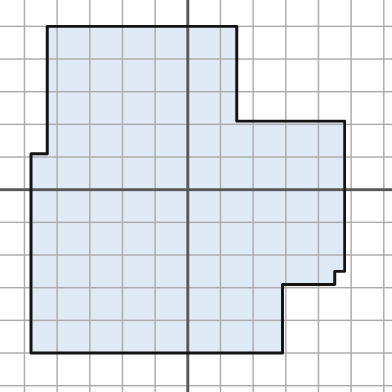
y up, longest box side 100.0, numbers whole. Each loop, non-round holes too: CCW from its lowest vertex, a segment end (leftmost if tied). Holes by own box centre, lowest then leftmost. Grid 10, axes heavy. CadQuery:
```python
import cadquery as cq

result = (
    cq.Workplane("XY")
    .moveTo(-48.0, -50.0)
    .lineTo(29.0, -50.0)
    .lineTo(29.0, -29.0)
    .lineTo(45.0, -29.0)
    .lineTo(45.0, -25.0)
    .lineTo(48.0, -25.0)
    .lineTo(48.0, 21.0)
    .lineTo(15.0, 21.0)
    .lineTo(15.0, 50.0)
    .lineTo(-43.0, 50.0)
    .lineTo(-43.0, 11.0)
    .lineTo(-48.0, 11.0)
    .close()
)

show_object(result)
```